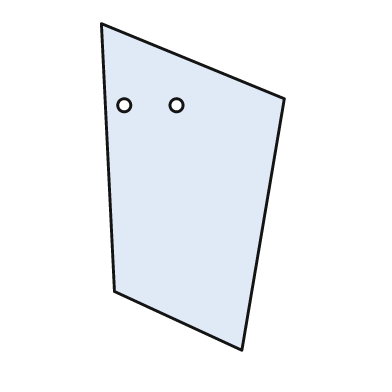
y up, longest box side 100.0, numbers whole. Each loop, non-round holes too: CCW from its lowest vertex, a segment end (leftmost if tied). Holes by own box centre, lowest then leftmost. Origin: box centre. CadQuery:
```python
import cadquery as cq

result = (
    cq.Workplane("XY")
    .moveTo(15.0, -50.0)
    .lineTo(28.0, 27.0)
    .lineTo(-28.0, 50.0)
    .lineTo(-24.0, -32.0)
    .close()
    .moveTo(-21.0, 25.0)
    .circle(2.0)
    .moveTo(-5.0, 25.0)
    .circle(2.0)
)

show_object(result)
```